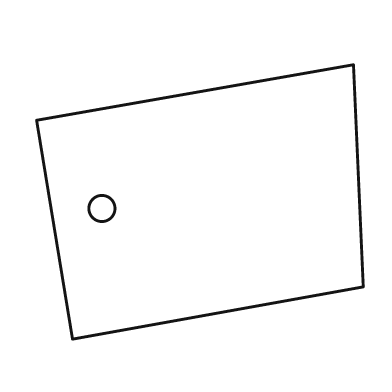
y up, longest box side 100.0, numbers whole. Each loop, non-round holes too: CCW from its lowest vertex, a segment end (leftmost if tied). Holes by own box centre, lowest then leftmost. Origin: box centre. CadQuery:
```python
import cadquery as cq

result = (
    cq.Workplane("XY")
    .moveTo(-39.0, -42.0)
    .lineTo(50.0, -26.0)
    .lineTo(47.0, 42.0)
    .lineTo(-50.0, 25.0)
    .close()
    .moveTo(-30.0, -2.0)
    .circle(4.0)
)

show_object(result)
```